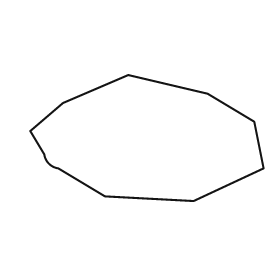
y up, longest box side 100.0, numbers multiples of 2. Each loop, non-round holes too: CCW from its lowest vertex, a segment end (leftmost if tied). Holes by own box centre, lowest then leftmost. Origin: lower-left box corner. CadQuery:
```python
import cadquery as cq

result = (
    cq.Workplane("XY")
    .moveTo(70.0, 0.0)
    .lineTo(100.0, 14.0)
    .lineTo(96.0, 34.0)
    .lineTo(76.0, 46.0)
    .lineTo(42.0, 54.0)
    .lineTo(14.0, 42.0)
    .lineTo(0.0, 30.0)
    .lineTo(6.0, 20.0)
    .threePointArc((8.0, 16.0), (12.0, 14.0))
    .lineTo(32.0, 2.0)
    .close()
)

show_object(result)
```